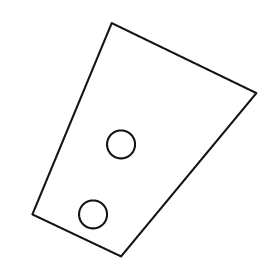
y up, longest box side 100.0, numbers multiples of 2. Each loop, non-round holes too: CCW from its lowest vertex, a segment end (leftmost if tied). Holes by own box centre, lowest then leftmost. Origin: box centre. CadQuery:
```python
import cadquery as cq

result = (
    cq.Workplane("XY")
    .moveTo(-10.0, -50.0)
    .lineTo(48.0, 20.0)
    .lineTo(-14.0, 50.0)
    .lineTo(-48.0, -32.0)
    .close()
    .moveTo(-22.0, -32.0)
    .circle(6.0)
    .moveTo(-10.0, -2.0)
    .circle(6.0)
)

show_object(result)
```